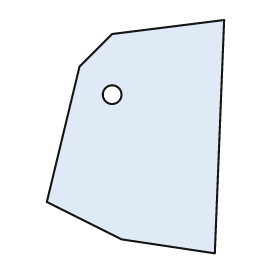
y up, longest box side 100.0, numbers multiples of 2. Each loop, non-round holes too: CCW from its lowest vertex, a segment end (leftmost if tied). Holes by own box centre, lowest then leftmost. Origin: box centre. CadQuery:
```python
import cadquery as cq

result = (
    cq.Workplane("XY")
    .moveTo(34.0, -50.0)
    .lineTo(38.0, 50.0)
    .lineTo(-10.0, 44.0)
    .lineTo(-24.0, 30.0)
    .lineTo(-38.0, -28.0)
    .lineTo(-6.0, -44.0)
    .close()
    .moveTo(-10.0, 18.0)
    .circle(4.0)
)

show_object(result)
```